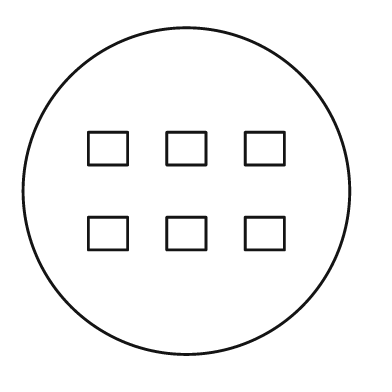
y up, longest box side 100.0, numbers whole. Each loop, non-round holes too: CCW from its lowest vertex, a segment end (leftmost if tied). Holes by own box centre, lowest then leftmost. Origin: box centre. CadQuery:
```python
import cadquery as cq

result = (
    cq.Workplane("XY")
    .moveTo(0.0, 0.0)
    .circle(50.0)
    .moveTo(-30.0, -18.0)
    .lineTo(-18.0, -18.0)
    .lineTo(-18.0, -8.0)
    .lineTo(-30.0, -8.0)
    .close()
    .moveTo(-6.0, -18.0)
    .lineTo(6.0, -18.0)
    .lineTo(6.0, -8.0)
    .lineTo(-6.0, -8.0)
    .close()
    .moveTo(18.0, -18.0)
    .lineTo(30.0, -18.0)
    .lineTo(30.0, -8.0)
    .lineTo(18.0, -8.0)
    .close()
    .moveTo(-30.0, 8.0)
    .lineTo(-18.0, 8.0)
    .lineTo(-18.0, 18.0)
    .lineTo(-30.0, 18.0)
    .close()
    .moveTo(-6.0, 8.0)
    .lineTo(6.0, 8.0)
    .lineTo(6.0, 18.0)
    .lineTo(-6.0, 18.0)
    .close()
    .moveTo(18.0, 8.0)
    .lineTo(30.0, 8.0)
    .lineTo(30.0, 18.0)
    .lineTo(18.0, 18.0)
    .close()
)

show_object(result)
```